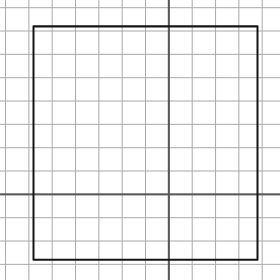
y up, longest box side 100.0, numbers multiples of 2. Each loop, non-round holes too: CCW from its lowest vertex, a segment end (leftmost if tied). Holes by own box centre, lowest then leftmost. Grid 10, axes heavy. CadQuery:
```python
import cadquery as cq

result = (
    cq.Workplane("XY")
    .moveTo(-58.0, -28.0)
    .lineTo(38.0, -28.0)
    .lineTo(38.0, 72.0)
    .lineTo(-58.0, 72.0)
    .close()
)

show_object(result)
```